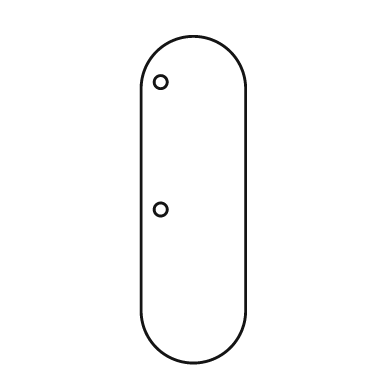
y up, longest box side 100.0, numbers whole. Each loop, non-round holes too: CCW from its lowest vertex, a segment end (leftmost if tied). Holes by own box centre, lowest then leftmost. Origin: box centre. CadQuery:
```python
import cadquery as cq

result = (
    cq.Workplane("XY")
    .moveTo(-16.0, -34.0)
    .threePointArc((0.0, -50.0), (16.0, -34.0))
    .lineTo(16.0, 34.0)
    .threePointArc((0.0, 50.0), (-16.0, 34.0))
    .close()
    .moveTo(-10.0, -3.0)
    .circle(2.0)
    .moveTo(-10.0, 36.0)
    .circle(2.0)
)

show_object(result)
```